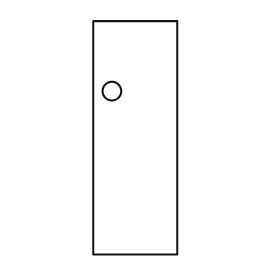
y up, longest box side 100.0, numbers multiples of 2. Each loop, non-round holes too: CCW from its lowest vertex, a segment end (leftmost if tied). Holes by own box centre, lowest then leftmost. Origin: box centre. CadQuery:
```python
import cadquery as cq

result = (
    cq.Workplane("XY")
    .moveTo(-18.0, -50.0)
    .lineTo(18.0, -50.0)
    .lineTo(18.0, 50.0)
    .lineTo(-18.0, 50.0)
    .close()
    .moveTo(-10.0, 20.0)
    .circle(4.0)
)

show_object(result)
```